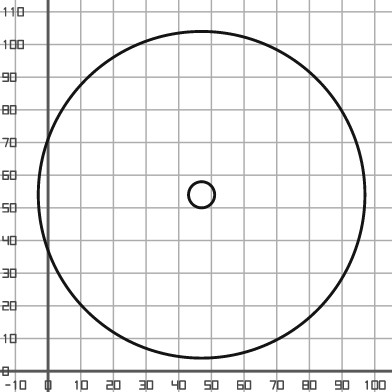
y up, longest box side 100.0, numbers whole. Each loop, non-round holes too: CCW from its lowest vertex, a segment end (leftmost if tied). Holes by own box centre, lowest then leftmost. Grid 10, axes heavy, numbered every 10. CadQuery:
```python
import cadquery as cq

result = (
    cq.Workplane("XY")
    .moveTo(47.0, 54.0)
    .circle(50.0)
    .moveTo(47.0, 54.0)
    .circle(4.0)
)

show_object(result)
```